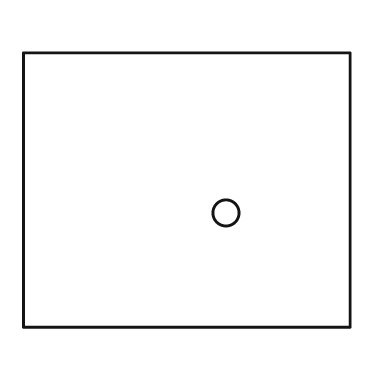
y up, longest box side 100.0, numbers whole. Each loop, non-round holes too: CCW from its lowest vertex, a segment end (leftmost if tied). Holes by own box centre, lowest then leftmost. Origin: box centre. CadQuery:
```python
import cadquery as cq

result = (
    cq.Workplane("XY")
    .moveTo(-50.0, -42.0)
    .lineTo(50.0, -42.0)
    .lineTo(50.0, 42.0)
    .lineTo(-50.0, 42.0)
    .close()
    .moveTo(12.0, -7.0)
    .circle(4.0)
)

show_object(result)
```